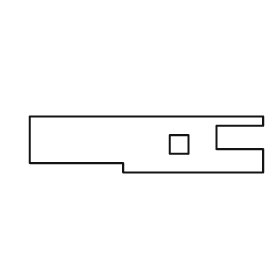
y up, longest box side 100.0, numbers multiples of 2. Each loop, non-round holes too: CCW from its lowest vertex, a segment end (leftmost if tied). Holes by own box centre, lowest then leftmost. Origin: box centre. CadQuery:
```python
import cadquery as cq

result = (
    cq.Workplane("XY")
    .moveTo(-10.0, -12.0)
    .lineTo(50.0, -12.0)
    .lineTo(50.0, -2.0)
    .lineTo(30.0, -2.0)
    .lineTo(30.0, 8.0)
    .lineTo(50.0, 8.0)
    .lineTo(50.0, 12.0)
    .lineTo(-50.0, 12.0)
    .lineTo(-50.0, -8.0)
    .lineTo(-10.0, -8.0)
    .close()
    .moveTo(10.0, -4.0)
    .lineTo(18.0, -4.0)
    .lineTo(18.0, 4.0)
    .lineTo(10.0, 4.0)
    .close()
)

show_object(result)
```